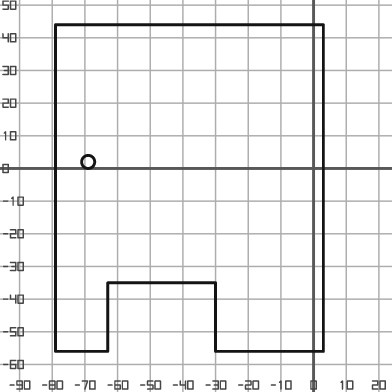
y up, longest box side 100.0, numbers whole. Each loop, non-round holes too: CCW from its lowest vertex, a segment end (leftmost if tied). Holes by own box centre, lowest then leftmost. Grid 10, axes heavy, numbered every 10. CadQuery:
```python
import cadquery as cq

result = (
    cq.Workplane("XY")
    .moveTo(-79.0, -56.0)
    .lineTo(-63.0, -56.0)
    .lineTo(-63.0, -35.0)
    .lineTo(-30.0, -35.0)
    .lineTo(-30.0, -56.0)
    .lineTo(3.0, -56.0)
    .lineTo(3.0, 44.0)
    .lineTo(-79.0, 44.0)
    .close()
    .moveTo(-69.0, 2.0)
    .circle(2.0)
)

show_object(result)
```